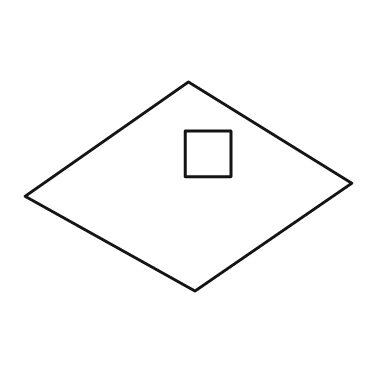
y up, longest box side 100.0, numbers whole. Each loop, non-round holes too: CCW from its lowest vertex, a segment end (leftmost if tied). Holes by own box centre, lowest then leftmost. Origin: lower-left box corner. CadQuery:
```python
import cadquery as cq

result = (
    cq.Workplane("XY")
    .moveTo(52.0, 0.0)
    .lineTo(100.0, 33.0)
    .lineTo(50.0, 64.0)
    .lineTo(0.0, 29.0)
    .close()
    .moveTo(49.0, 35.0)
    .lineTo(63.0, 35.0)
    .lineTo(63.0, 49.0)
    .lineTo(49.0, 49.0)
    .close()
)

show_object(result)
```